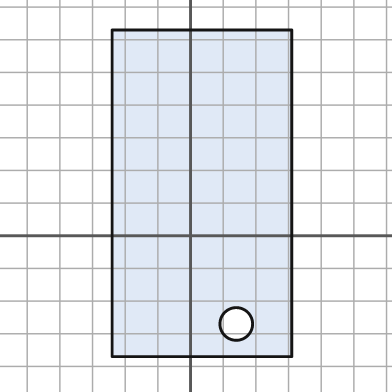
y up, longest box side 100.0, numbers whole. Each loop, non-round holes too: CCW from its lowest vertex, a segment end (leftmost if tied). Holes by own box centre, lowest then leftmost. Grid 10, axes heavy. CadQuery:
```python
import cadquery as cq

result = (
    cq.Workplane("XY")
    .moveTo(-24.0, -37.0)
    .lineTo(31.0, -37.0)
    .lineTo(31.0, 63.0)
    .lineTo(-24.0, 63.0)
    .close()
    .moveTo(14.0, -27.0)
    .circle(5.0)
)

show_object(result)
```